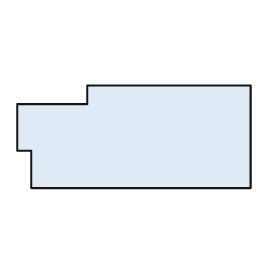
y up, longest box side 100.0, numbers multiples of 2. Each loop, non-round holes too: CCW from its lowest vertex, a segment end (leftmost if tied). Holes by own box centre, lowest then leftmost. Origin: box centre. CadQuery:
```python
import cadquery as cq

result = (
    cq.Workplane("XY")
    .moveTo(-44.0, -22.0)
    .lineTo(50.0, -22.0)
    .lineTo(50.0, 22.0)
    .lineTo(-20.0, 22.0)
    .lineTo(-20.0, 14.0)
    .lineTo(-50.0, 14.0)
    .lineTo(-50.0, -6.0)
    .lineTo(-44.0, -6.0)
    .close()
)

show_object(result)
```